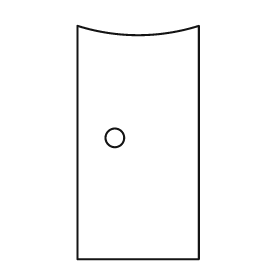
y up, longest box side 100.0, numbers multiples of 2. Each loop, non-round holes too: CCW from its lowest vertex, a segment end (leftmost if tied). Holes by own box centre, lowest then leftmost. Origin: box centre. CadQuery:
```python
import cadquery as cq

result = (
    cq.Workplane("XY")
    .moveTo(-26.0, -50.0)
    .lineTo(26.0, -50.0)
    .lineTo(26.0, 50.0)
    .threePointArc((0.0, 46.0), (-26.0, 50.0))
    .close()
    .moveTo(-10.0, 2.0)
    .circle(4.0)
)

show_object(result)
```